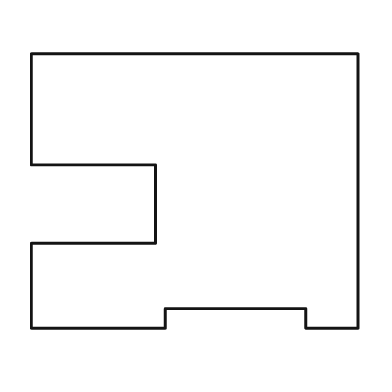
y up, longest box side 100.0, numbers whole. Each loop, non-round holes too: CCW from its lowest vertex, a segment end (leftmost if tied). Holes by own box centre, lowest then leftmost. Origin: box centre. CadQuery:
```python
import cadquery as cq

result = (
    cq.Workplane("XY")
    .moveTo(-50.0, -42.0)
    .lineTo(-9.0, -42.0)
    .lineTo(-9.0, -36.0)
    .lineTo(34.0, -36.0)
    .lineTo(34.0, -42.0)
    .lineTo(50.0, -42.0)
    .lineTo(50.0, 42.0)
    .lineTo(-50.0, 42.0)
    .lineTo(-50.0, 8.0)
    .lineTo(-12.0, 8.0)
    .lineTo(-12.0, -16.0)
    .lineTo(-50.0, -16.0)
    .close()
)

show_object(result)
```